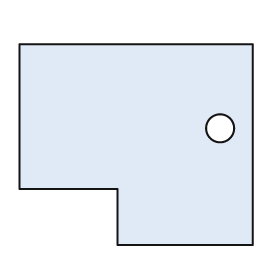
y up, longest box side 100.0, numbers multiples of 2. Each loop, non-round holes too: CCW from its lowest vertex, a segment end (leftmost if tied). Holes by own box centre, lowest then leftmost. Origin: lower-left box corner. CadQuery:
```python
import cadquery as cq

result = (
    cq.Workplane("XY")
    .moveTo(42.0, 0.0)
    .lineTo(100.0, 0.0)
    .lineTo(100.0, 86.0)
    .lineTo(0.0, 86.0)
    .lineTo(0.0, 24.0)
    .lineTo(42.0, 24.0)
    .close()
    .moveTo(86.0, 50.0)
    .circle(6.0)
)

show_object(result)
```